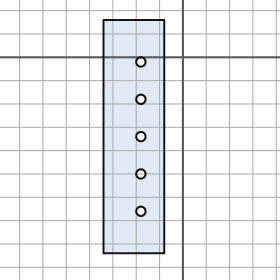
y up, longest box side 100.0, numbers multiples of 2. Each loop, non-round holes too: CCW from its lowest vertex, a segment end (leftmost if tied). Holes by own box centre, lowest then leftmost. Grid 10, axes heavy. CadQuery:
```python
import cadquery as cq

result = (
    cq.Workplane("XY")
    .moveTo(-34.0, -84.0)
    .lineTo(-8.0, -84.0)
    .lineTo(-8.0, 16.0)
    .lineTo(-34.0, 16.0)
    .close()
    .moveTo(-18.0, -66.0)
    .circle(2.0)
    .moveTo(-18.0, -50.0)
    .circle(2.0)
    .moveTo(-18.0, -34.0)
    .circle(2.0)
    .moveTo(-18.0, -18.0)
    .circle(2.0)
    .moveTo(-18.0, -2.0)
    .circle(2.0)
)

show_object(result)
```